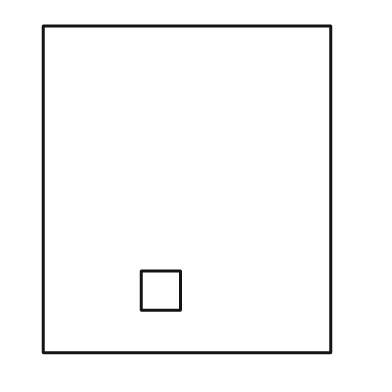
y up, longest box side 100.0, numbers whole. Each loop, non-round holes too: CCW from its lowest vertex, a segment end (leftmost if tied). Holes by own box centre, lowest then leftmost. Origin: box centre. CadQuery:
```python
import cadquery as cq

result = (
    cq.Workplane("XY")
    .moveTo(-44.0, -50.0)
    .lineTo(44.0, -50.0)
    .lineTo(44.0, 50.0)
    .lineTo(-44.0, 50.0)
    .close()
    .moveTo(-14.0, -37.0)
    .lineTo(-2.0, -37.0)
    .lineTo(-2.0, -25.0)
    .lineTo(-14.0, -25.0)
    .close()
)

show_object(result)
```